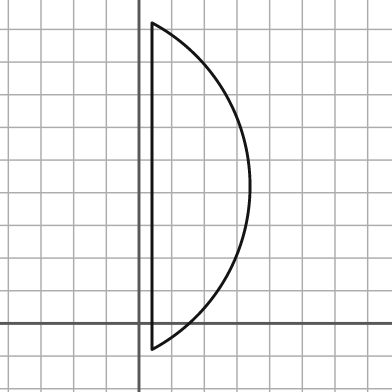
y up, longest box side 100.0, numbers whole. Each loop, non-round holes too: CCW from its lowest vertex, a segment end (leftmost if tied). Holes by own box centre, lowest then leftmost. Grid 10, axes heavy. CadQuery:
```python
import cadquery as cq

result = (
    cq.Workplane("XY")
    .moveTo(4.0, -8.0)
    .threePointArc((34.0, 42.0), (4.0, 92.0))
    .close()
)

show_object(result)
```